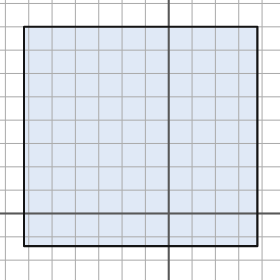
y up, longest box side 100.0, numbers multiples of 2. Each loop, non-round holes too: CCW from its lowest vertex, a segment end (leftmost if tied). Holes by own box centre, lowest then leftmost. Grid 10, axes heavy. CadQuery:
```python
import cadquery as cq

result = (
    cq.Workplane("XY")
    .moveTo(-62.0, -14.0)
    .lineTo(38.0, -14.0)
    .lineTo(38.0, 80.0)
    .lineTo(-62.0, 80.0)
    .close()
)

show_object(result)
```